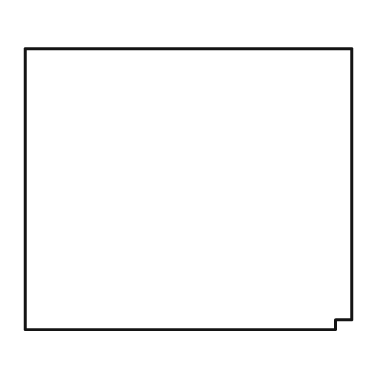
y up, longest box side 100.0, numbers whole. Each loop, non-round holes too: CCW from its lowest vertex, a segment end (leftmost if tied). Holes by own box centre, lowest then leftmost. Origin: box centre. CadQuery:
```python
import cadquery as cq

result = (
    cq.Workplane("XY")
    .moveTo(-50.0, -43.0)
    .lineTo(45.0, -43.0)
    .lineTo(45.0, -40.0)
    .lineTo(50.0, -40.0)
    .lineTo(50.0, 43.0)
    .lineTo(-50.0, 43.0)
    .close()
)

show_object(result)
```